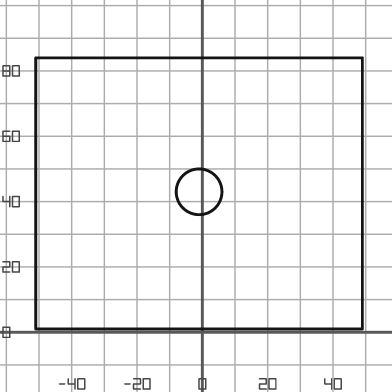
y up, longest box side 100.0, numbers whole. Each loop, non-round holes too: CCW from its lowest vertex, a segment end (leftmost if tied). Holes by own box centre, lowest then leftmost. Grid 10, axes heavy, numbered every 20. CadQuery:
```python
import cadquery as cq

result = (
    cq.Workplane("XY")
    .moveTo(-51.0, 1.0)
    .lineTo(49.0, 1.0)
    .lineTo(49.0, 84.0)
    .lineTo(-51.0, 84.0)
    .close()
    .moveTo(-1.0, 43.0)
    .circle(7.0)
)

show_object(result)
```